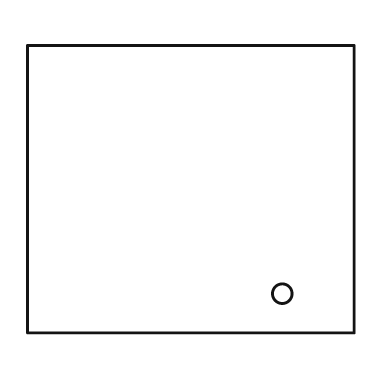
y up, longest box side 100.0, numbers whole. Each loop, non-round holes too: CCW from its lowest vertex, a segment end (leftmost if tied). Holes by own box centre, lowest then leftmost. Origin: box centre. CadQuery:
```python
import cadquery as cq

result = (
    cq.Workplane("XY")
    .moveTo(-50.0, -44.0)
    .lineTo(50.0, -44.0)
    .lineTo(50.0, 44.0)
    .lineTo(-50.0, 44.0)
    .close()
    .moveTo(28.0, -32.0)
    .circle(3.0)
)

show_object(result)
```